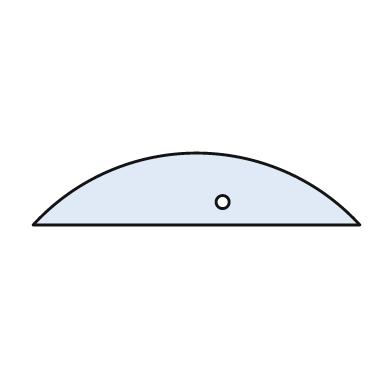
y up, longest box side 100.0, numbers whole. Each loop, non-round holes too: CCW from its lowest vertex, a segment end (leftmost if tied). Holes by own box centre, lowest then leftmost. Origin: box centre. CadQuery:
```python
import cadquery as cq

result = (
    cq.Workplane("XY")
    .moveTo(-50.0, -11.0)
    .lineTo(50.0, -11.0)
    .threePointArc((0.0, 11.0), (-50.0, -11.0))
    .close()
    .moveTo(8.0, -4.0)
    .circle(2.0)
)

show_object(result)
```